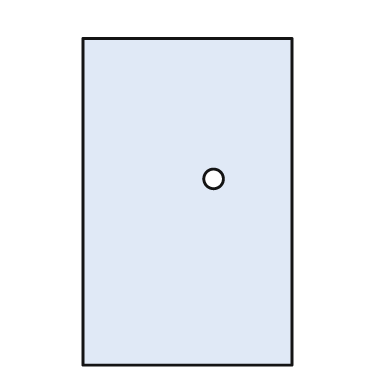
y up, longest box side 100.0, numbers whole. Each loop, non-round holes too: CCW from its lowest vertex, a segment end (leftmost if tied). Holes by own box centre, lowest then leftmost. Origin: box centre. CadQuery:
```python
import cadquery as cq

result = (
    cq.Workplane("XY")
    .moveTo(-32.0, -50.0)
    .lineTo(32.0, -50.0)
    .lineTo(32.0, 50.0)
    .lineTo(-32.0, 50.0)
    .close()
    .moveTo(8.0, 7.0)
    .circle(3.0)
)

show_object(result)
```